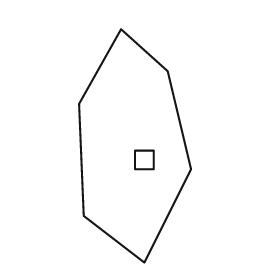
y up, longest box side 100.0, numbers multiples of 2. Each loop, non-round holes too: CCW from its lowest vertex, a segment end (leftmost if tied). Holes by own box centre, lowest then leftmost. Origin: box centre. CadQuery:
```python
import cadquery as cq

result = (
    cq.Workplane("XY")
    .moveTo(4.0, -50.0)
    .lineTo(24.0, -10.0)
    .lineTo(14.0, 32.0)
    .lineTo(-6.0, 50.0)
    .lineTo(-24.0, 18.0)
    .lineTo(-22.0, -30.0)
    .close()
    .moveTo(0.0, -10.0)
    .lineTo(8.0, -10.0)
    .lineTo(8.0, -2.0)
    .lineTo(0.0, -2.0)
    .close()
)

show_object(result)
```